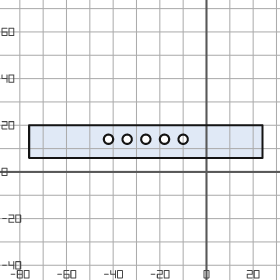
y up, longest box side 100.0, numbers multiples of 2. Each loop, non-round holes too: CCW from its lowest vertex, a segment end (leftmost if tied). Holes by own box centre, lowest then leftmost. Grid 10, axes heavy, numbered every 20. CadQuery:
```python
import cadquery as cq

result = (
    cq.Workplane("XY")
    .moveTo(-76.0, 6.0)
    .lineTo(24.0, 6.0)
    .lineTo(24.0, 20.0)
    .lineTo(-76.0, 20.0)
    .close()
    .moveTo(-42.0, 14.0)
    .circle(2.0)
    .moveTo(-34.0, 14.0)
    .circle(2.0)
    .moveTo(-26.0, 14.0)
    .circle(2.0)
    .moveTo(-18.0, 14.0)
    .circle(2.0)
    .moveTo(-10.0, 14.0)
    .circle(2.0)
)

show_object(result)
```